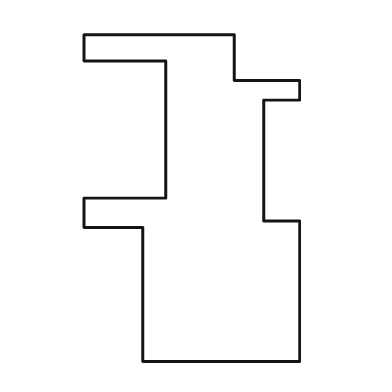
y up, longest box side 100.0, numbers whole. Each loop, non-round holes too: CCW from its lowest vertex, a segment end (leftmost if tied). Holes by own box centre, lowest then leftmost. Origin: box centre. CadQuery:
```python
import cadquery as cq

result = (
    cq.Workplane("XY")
    .moveTo(-15.0, -50.0)
    .lineTo(33.0, -50.0)
    .lineTo(33.0, -7.0)
    .lineTo(22.0, -7.0)
    .lineTo(22.0, 30.0)
    .lineTo(33.0, 30.0)
    .lineTo(33.0, 36.0)
    .lineTo(13.0, 36.0)
    .lineTo(13.0, 50.0)
    .lineTo(-33.0, 50.0)
    .lineTo(-33.0, 42.0)
    .lineTo(-8.0, 42.0)
    .lineTo(-8.0, 0.0)
    .lineTo(-33.0, 0.0)
    .lineTo(-33.0, -9.0)
    .lineTo(-15.0, -9.0)
    .close()
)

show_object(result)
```